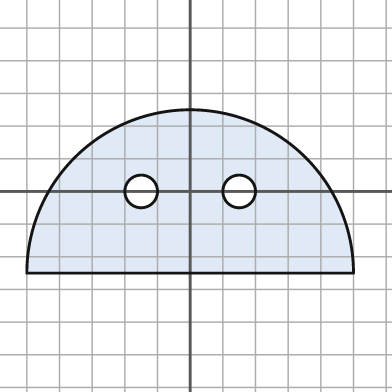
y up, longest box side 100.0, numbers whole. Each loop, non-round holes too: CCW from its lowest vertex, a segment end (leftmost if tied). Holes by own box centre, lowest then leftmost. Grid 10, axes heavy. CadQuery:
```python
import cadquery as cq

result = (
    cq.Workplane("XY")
    .moveTo(-50.0, -25.0)
    .lineTo(50.0, -25.0)
    .threePointArc((0.0, 25.0), (-50.0, -25.0))
    .close()
    .moveTo(-15.0, 0.0)
    .circle(5.0)
    .moveTo(15.0, 0.0)
    .circle(5.0)
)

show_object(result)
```